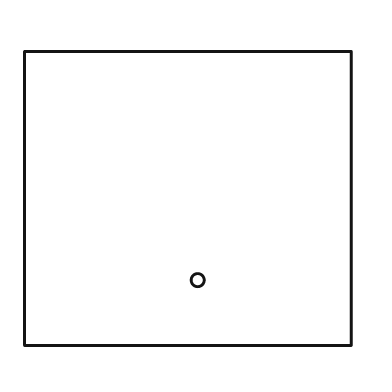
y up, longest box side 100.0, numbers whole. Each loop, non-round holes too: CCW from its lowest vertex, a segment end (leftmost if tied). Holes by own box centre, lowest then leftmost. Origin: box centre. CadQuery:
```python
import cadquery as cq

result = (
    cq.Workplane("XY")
    .moveTo(-50.0, -45.0)
    .lineTo(50.0, -45.0)
    .lineTo(50.0, 45.0)
    .lineTo(-50.0, 45.0)
    .close()
    .moveTo(3.0, -25.0)
    .circle(2.0)
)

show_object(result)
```